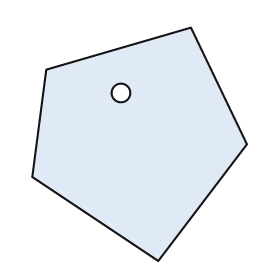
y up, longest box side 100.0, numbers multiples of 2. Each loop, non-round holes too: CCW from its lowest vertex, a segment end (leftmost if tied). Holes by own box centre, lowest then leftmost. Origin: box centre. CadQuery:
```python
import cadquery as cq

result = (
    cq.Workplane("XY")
    .moveTo(8.0, -50.0)
    .lineTo(46.0, 0.0)
    .lineTo(22.0, 50.0)
    .lineTo(-40.0, 32.0)
    .lineTo(-46.0, -14.0)
    .close()
    .moveTo(-8.0, 22.0)
    .circle(4.0)
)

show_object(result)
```